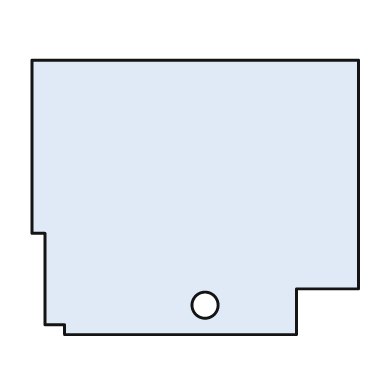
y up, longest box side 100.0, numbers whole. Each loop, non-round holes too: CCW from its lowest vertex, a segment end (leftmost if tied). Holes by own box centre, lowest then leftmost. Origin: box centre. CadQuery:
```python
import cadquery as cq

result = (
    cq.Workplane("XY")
    .moveTo(-40.0, -42.0)
    .lineTo(31.0, -42.0)
    .lineTo(31.0, -28.0)
    .lineTo(50.0, -28.0)
    .lineTo(50.0, 42.0)
    .lineTo(-50.0, 42.0)
    .lineTo(-50.0, -11.0)
    .lineTo(-46.0, -11.0)
    .lineTo(-46.0, -39.0)
    .lineTo(-40.0, -39.0)
    .close()
    .moveTo(3.0, -33.0)
    .circle(4.0)
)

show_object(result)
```